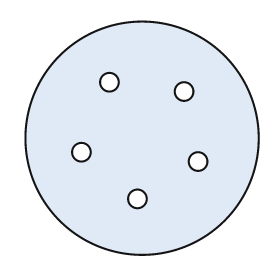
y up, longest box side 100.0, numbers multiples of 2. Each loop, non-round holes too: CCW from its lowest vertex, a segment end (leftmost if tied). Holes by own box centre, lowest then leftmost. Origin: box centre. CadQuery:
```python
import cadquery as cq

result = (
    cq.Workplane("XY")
    .moveTo(0.0, 0.0)
    .circle(50.0)
    .moveTo(-2.0, -26.0)
    .circle(4.0)
    .moveTo(24.0, -10.0)
    .circle(4.0)
    .moveTo(-26.0, -6.0)
    .circle(4.0)
    .moveTo(18.0, 20.0)
    .circle(4.0)
    .moveTo(-14.0, 24.0)
    .circle(4.0)
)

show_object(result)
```